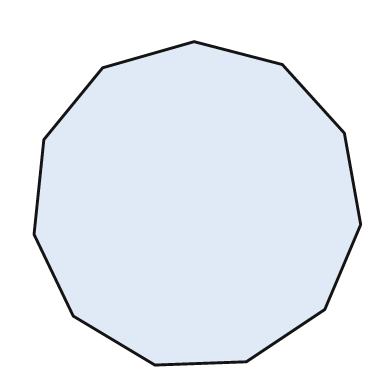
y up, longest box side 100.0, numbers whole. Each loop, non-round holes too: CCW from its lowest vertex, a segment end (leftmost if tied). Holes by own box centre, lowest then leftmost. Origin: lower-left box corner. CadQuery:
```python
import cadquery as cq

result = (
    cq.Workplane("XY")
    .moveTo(37.0, 0.0)
    .lineTo(65.0, 1.0)
    .lineTo(89.0, 17.0)
    .lineTo(100.0, 43.0)
    .lineTo(95.0, 71.0)
    .lineTo(76.0, 92.0)
    .lineTo(49.0, 99.0)
    .lineTo(21.0, 91.0)
    .lineTo(3.0, 69.0)
    .lineTo(0.0, 40.0)
    .lineTo(12.0, 15.0)
    .close()
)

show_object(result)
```